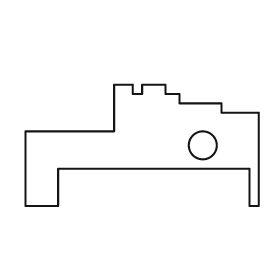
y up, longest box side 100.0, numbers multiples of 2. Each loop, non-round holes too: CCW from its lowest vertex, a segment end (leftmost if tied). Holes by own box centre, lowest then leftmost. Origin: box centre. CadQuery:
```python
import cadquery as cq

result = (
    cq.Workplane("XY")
    .moveTo(-50.0, -26.0)
    .lineTo(-36.0, -26.0)
    .lineTo(-36.0, -10.0)
    .lineTo(46.0, -10.0)
    .lineTo(46.0, -26.0)
    .lineTo(50.0, -26.0)
    .lineTo(50.0, 14.0)
    .lineTo(34.0, 14.0)
    .lineTo(34.0, 18.0)
    .lineTo(16.0, 18.0)
    .lineTo(16.0, 22.0)
    .lineTo(10.0, 22.0)
    .lineTo(10.0, 26.0)
    .lineTo(0.0, 26.0)
    .lineTo(0.0, 22.0)
    .lineTo(-4.0, 22.0)
    .lineTo(-4.0, 26.0)
    .lineTo(-12.0, 26.0)
    .lineTo(-12.0, 6.0)
    .lineTo(-50.0, 6.0)
    .close()
    .moveTo(26.0, 0.0)
    .circle(6.0)
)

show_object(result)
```